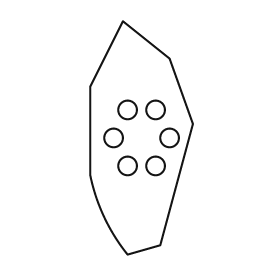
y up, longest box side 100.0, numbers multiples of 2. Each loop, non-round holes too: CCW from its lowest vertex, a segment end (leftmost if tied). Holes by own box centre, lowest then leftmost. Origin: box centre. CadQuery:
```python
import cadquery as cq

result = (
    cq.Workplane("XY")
    .moveTo(-6.0, -50.0)
    .lineTo(8.0, -46.0)
    .lineTo(22.0, 6.0)
    .lineTo(12.0, 34.0)
    .lineTo(-8.0, 50.0)
    .lineTo(-22.0, 22.0)
    .lineTo(-22.0, -16.0)
    .threePointArc((-16.0, -34.0), (-6.0, -50.0))
    .close()
    .moveTo(-6.0, -12.0)
    .circle(4.0)
    .moveTo(6.0, -12.0)
    .circle(4.0)
    .moveTo(-12.0, 0.0)
    .circle(4.0)
    .moveTo(12.0, 0.0)
    .circle(4.0)
    .moveTo(-6.0, 12.0)
    .circle(4.0)
    .moveTo(6.0, 12.0)
    .circle(4.0)
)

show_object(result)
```